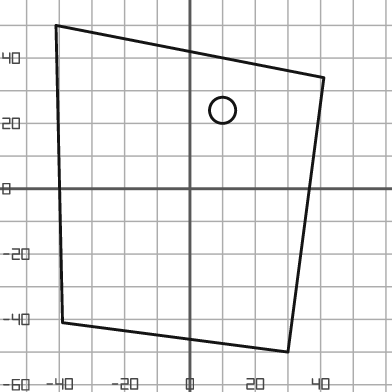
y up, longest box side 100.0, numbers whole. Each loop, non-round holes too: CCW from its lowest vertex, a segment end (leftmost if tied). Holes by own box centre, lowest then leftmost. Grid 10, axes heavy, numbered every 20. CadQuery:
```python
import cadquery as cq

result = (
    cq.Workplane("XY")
    .moveTo(30.0, -50.0)
    .lineTo(41.0, 34.0)
    .lineTo(-41.0, 50.0)
    .lineTo(-39.0, -41.0)
    .close()
    .moveTo(10.0, 24.0)
    .circle(4.0)
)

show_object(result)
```